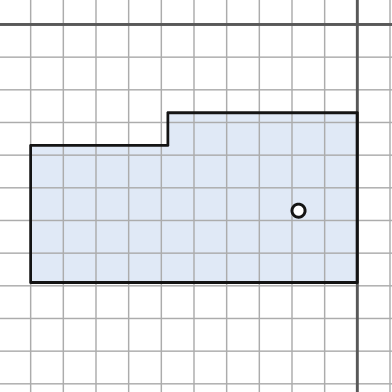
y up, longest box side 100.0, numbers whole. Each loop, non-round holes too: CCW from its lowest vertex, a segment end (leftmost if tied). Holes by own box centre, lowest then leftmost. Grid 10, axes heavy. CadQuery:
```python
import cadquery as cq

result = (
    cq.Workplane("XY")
    .moveTo(-100.0, -79.0)
    .lineTo(0.0, -79.0)
    .lineTo(0.0, -27.0)
    .lineTo(-58.0, -27.0)
    .lineTo(-58.0, -37.0)
    .lineTo(-100.0, -37.0)
    .close()
    .moveTo(-18.0, -57.0)
    .circle(2.0)
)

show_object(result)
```